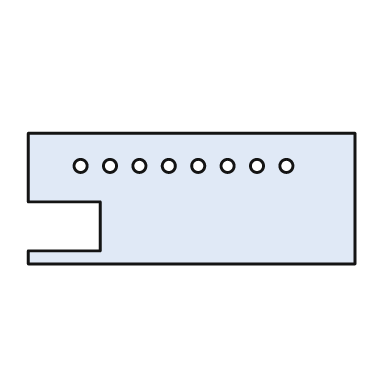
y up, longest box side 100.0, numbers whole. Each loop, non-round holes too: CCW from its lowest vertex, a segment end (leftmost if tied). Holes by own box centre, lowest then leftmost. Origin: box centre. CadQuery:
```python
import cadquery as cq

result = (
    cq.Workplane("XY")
    .moveTo(-50.0, -20.0)
    .lineTo(50.0, -20.0)
    .lineTo(50.0, 20.0)
    .lineTo(-50.0, 20.0)
    .lineTo(-50.0, -1.0)
    .lineTo(-28.0, -1.0)
    .lineTo(-28.0, -16.0)
    .lineTo(-50.0, -16.0)
    .close()
    .moveTo(-34.0, 10.0)
    .circle(2.0)
    .moveTo(-25.0, 10.0)
    .circle(2.0)
    .moveTo(-16.0, 10.0)
    .circle(2.0)
    .moveTo(-7.0, 10.0)
    .circle(2.0)
    .moveTo(2.0, 10.0)
    .circle(2.0)
    .moveTo(11.0, 10.0)
    .circle(2.0)
    .moveTo(20.0, 10.0)
    .circle(2.0)
    .moveTo(29.0, 10.0)
    .circle(2.0)
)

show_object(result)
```